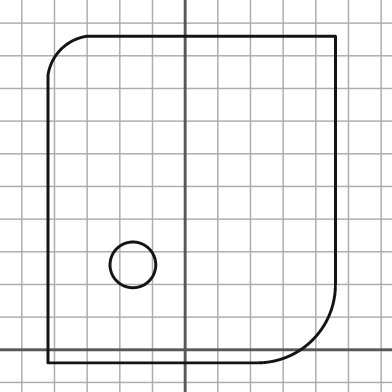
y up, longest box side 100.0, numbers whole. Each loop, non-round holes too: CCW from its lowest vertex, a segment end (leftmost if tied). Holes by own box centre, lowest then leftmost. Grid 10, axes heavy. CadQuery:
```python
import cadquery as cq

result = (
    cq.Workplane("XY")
    .moveTo(-42.0, -4.0)
    .lineTo(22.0, -4.0)
    .threePointArc((39.0, 3.0), (46.0, 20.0))
    .lineTo(46.0, 96.0)
    .lineTo(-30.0, 96.0)
    .threePointArc((-38.0, 92.0), (-42.0, 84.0))
    .close()
    .moveTo(-16.0, 26.0)
    .circle(7.0)
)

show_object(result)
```